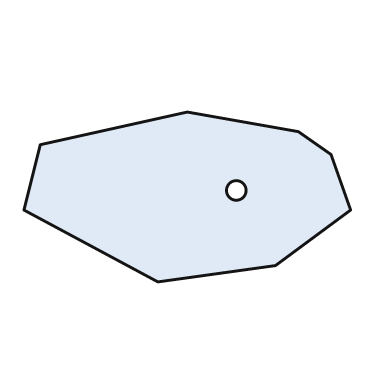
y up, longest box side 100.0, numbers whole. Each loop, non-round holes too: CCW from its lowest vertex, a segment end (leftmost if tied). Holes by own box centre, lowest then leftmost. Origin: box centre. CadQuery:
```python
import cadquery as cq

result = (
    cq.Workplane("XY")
    .moveTo(-9.0, -26.0)
    .lineTo(27.0, -21.0)
    .lineTo(50.0, -4.0)
    .lineTo(44.0, 13.0)
    .lineTo(34.0, 20.0)
    .lineTo(0.0, 26.0)
    .lineTo(-45.0, 16.0)
    .lineTo(-50.0, -4.0)
    .close()
    .moveTo(15.0, 2.0)
    .circle(3.0)
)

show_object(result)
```